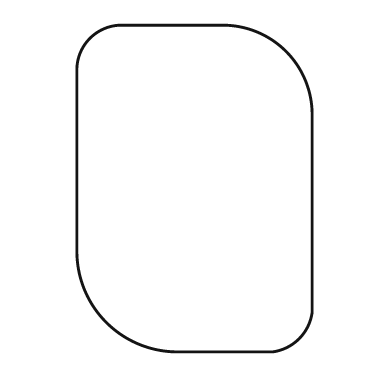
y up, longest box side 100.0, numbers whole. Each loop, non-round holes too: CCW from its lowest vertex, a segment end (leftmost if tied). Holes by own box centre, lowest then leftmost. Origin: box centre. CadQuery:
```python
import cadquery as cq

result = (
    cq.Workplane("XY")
    .moveTo(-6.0, -50.0)
    .lineTo(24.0, -50.0)
    .threePointArc((32.0, -46.0), (36.0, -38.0))
    .lineTo(36.0, 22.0)
    .threePointArc((28.0, 42.0), (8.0, 50.0))
    .lineTo(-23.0, 50.0)
    .threePointArc((-32.0, 46.0), (-36.0, 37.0))
    .lineTo(-36.0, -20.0)
    .threePointArc((-27.0, -41.0), (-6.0, -50.0))
    .close()
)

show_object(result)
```